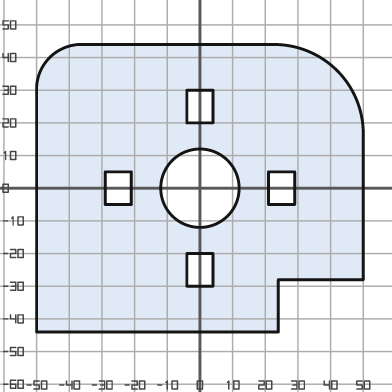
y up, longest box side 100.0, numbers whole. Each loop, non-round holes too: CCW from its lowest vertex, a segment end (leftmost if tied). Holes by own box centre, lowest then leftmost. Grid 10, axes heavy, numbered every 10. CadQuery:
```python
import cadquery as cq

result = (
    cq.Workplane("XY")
    .moveTo(-50.0, -44.0)
    .lineTo(24.0, -44.0)
    .lineTo(24.0, -28.0)
    .lineTo(50.0, -28.0)
    .lineTo(50.0, 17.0)
    .threePointArc((42.0, 36.0), (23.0, 44.0))
    .lineTo(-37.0, 44.0)
    .threePointArc((-46.0, 40.0), (-50.0, 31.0))
    .close()
    .moveTo(-4.0, -30.0)
    .lineTo(4.0, -30.0)
    .lineTo(4.0, -20.0)
    .lineTo(-4.0, -20.0)
    .close()
    .moveTo(-29.0, -5.0)
    .lineTo(-21.0, -5.0)
    .lineTo(-21.0, 5.0)
    .lineTo(-29.0, 5.0)
    .close()
    .moveTo(0.0, 0.0)
    .circle(12.0)
    .moveTo(21.0, -5.0)
    .lineTo(29.0, -5.0)
    .lineTo(29.0, 5.0)
    .lineTo(21.0, 5.0)
    .close()
    .moveTo(-4.0, 20.0)
    .lineTo(4.0, 20.0)
    .lineTo(4.0, 30.0)
    .lineTo(-4.0, 30.0)
    .close()
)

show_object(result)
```